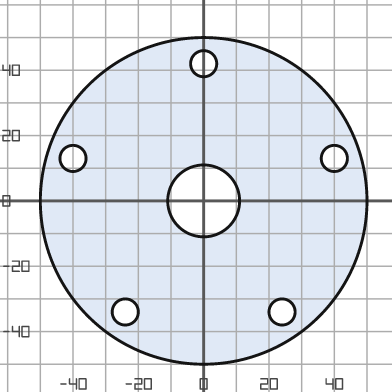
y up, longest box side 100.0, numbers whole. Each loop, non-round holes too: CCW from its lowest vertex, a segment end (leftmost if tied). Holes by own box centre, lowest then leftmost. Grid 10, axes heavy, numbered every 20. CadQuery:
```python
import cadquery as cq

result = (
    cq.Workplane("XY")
    .moveTo(0.0, 0.0)
    .circle(50.0)
    .moveTo(-24.0, -34.0)
    .circle(4.0)
    .moveTo(24.0, -34.0)
    .circle(4.0)
    .moveTo(0.0, 0.0)
    .circle(11.0)
    .moveTo(-40.0, 13.0)
    .circle(4.0)
    .moveTo(40.0, 13.0)
    .circle(4.0)
    .moveTo(0.0, 42.0)
    .circle(4.0)
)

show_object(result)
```